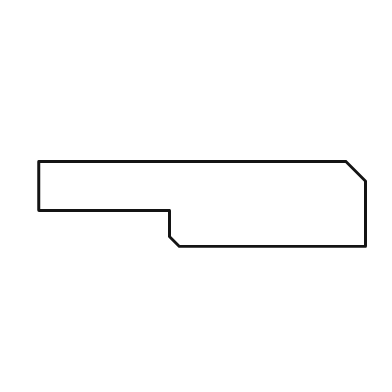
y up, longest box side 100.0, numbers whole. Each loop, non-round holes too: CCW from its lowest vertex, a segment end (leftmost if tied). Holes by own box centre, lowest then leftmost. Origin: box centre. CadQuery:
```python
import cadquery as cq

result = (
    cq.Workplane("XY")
    .moveTo(-7.0, -13.0)
    .lineTo(50.0, -13.0)
    .lineTo(50.0, 7.0)
    .lineTo(44.0, 13.0)
    .lineTo(-50.0, 13.0)
    .lineTo(-50.0, -2.0)
    .lineTo(-10.0, -2.0)
    .lineTo(-10.0, -10.0)
    .close()
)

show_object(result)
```